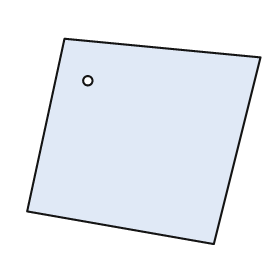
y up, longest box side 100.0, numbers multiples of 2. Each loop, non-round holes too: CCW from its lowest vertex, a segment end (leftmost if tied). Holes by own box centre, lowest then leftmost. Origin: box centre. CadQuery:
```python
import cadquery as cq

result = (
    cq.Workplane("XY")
    .moveTo(30.0, -44.0)
    .lineTo(50.0, 36.0)
    .lineTo(-34.0, 44.0)
    .lineTo(-50.0, -30.0)
    .close()
    .moveTo(-24.0, 26.0)
    .circle(2.0)
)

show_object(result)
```